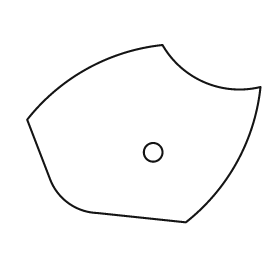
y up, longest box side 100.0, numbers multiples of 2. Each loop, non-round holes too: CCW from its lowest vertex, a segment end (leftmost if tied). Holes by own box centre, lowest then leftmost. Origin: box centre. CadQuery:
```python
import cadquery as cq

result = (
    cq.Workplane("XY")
    .moveTo(18.0, -38.0)
    .threePointArc((40.0, -12.0), (50.0, 20.0))
    .threePointArc((26.0, 22.0), (8.0, 38.0))
    .threePointArc((-24.0, 28.0), (-50.0, 6.0))
    .lineTo(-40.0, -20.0)
    .threePointArc((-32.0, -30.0), (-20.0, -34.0))
    .close()
    .moveTo(4.0, -8.0)
    .circle(4.0)
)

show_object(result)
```